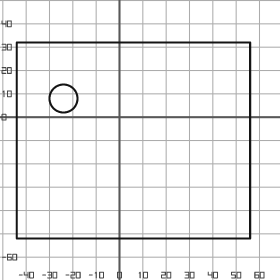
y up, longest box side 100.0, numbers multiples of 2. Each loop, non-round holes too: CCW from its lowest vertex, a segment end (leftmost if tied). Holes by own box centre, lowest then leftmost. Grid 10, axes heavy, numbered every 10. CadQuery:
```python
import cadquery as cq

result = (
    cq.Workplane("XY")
    .moveTo(-44.0, -52.0)
    .lineTo(56.0, -52.0)
    .lineTo(56.0, 32.0)
    .lineTo(-44.0, 32.0)
    .close()
    .moveTo(-24.0, 8.0)
    .circle(6.0)
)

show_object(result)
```